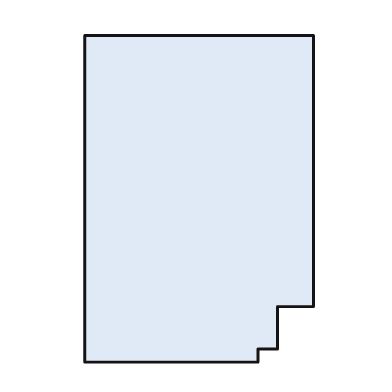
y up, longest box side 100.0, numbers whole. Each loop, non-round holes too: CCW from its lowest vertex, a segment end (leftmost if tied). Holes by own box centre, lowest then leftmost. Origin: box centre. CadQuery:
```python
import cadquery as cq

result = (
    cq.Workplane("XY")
    .moveTo(-35.0, -50.0)
    .lineTo(18.0, -50.0)
    .lineTo(18.0, -46.0)
    .lineTo(24.0, -46.0)
    .lineTo(24.0, -33.0)
    .lineTo(35.0, -33.0)
    .lineTo(35.0, 50.0)
    .lineTo(-35.0, 50.0)
    .close()
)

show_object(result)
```